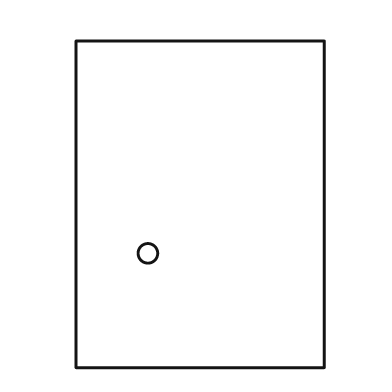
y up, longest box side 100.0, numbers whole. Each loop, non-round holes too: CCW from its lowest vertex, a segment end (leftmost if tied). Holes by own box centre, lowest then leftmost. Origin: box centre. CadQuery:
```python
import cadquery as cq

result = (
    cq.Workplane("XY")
    .moveTo(-38.0, -50.0)
    .lineTo(38.0, -50.0)
    .lineTo(38.0, 50.0)
    .lineTo(-38.0, 50.0)
    .close()
    .moveTo(-16.0, -15.0)
    .circle(3.0)
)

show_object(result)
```